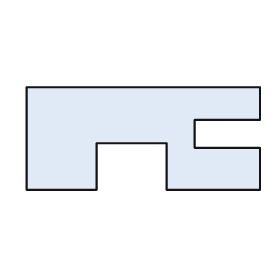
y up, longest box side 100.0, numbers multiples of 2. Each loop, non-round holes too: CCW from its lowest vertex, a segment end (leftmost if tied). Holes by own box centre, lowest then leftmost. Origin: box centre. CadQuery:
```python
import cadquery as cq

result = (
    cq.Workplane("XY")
    .moveTo(-50.0, -22.0)
    .lineTo(-20.0, -22.0)
    .lineTo(-20.0, -2.0)
    .lineTo(10.0, -2.0)
    .lineTo(10.0, -22.0)
    .lineTo(50.0, -22.0)
    .lineTo(50.0, -4.0)
    .lineTo(22.0, -4.0)
    .lineTo(22.0, 8.0)
    .lineTo(50.0, 8.0)
    .lineTo(50.0, 22.0)
    .lineTo(-50.0, 22.0)
    .close()
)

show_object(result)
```